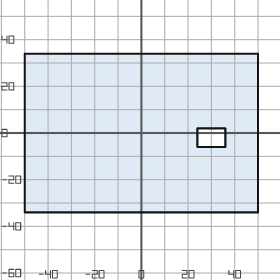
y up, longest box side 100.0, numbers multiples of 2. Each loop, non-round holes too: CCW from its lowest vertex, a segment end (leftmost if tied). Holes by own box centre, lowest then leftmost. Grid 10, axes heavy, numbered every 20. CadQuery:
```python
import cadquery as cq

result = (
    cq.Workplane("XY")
    .moveTo(-50.0, -34.0)
    .lineTo(50.0, -34.0)
    .lineTo(50.0, 34.0)
    .lineTo(-50.0, 34.0)
    .close()
    .moveTo(24.0, -6.0)
    .lineTo(36.0, -6.0)
    .lineTo(36.0, 2.0)
    .lineTo(24.0, 2.0)
    .close()
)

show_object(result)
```